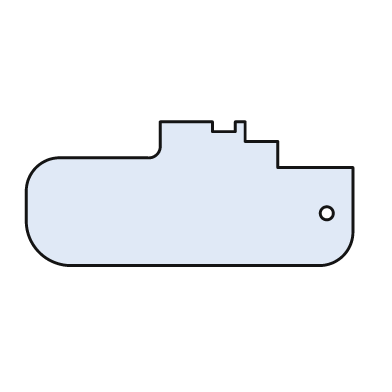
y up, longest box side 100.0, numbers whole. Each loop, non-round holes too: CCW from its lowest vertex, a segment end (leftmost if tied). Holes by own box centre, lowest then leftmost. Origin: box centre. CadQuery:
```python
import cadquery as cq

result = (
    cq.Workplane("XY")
    .moveTo(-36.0, -22.0)
    .lineTo(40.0, -22.0)
    .threePointArc((47.0, -19.0), (50.0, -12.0))
    .lineTo(50.0, 8.0)
    .lineTo(27.0, 8.0)
    .lineTo(27.0, 16.0)
    .lineTo(17.0, 16.0)
    .lineTo(17.0, 22.0)
    .lineTo(14.0, 22.0)
    .lineTo(14.0, 19.0)
    .lineTo(7.0, 19.0)
    .lineTo(7.0, 22.0)
    .lineTo(-9.0, 22.0)
    .lineTo(-9.0, 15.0)
    .threePointArc((-10.0, 12.0), (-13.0, 11.0))
    .lineTo(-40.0, 11.0)
    .threePointArc((-47.0, 8.0), (-50.0, 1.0))
    .lineTo(-50.0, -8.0)
    .threePointArc((-46.0, -18.0), (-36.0, -22.0))
    .close()
    .moveTo(42.0, -6.0)
    .circle(2.0)
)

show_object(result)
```